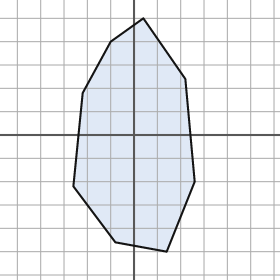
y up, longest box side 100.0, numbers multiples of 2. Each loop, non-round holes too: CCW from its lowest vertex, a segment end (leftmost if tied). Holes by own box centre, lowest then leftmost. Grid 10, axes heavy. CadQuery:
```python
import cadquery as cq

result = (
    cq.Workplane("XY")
    .moveTo(14.0, -50.0)
    .lineTo(26.0, -20.0)
    .lineTo(22.0, 24.0)
    .lineTo(4.0, 50.0)
    .lineTo(-10.0, 40.0)
    .lineTo(-22.0, 18.0)
    .lineTo(-26.0, -22.0)
    .lineTo(-8.0, -46.0)
    .close()
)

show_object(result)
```